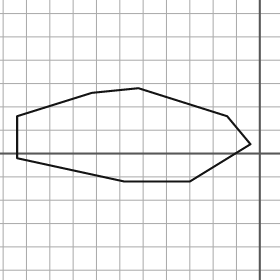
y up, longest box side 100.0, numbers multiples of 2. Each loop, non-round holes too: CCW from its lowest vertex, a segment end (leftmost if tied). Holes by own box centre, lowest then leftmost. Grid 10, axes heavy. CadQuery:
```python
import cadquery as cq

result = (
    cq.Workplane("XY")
    .moveTo(-58.0, -12.0)
    .lineTo(-30.0, -12.0)
    .lineTo(-4.0, 4.0)
    .lineTo(-14.0, 16.0)
    .lineTo(-52.0, 28.0)
    .lineTo(-72.0, 26.0)
    .lineTo(-104.0, 16.0)
    .lineTo(-104.0, -2.0)
    .close()
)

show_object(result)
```